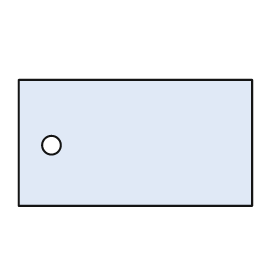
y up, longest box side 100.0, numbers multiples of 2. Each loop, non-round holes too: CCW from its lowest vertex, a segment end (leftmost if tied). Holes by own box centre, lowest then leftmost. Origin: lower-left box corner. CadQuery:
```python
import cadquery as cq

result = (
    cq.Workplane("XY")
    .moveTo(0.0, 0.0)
    .lineTo(100.0, 0.0)
    .lineTo(100.0, 54.0)
    .lineTo(0.0, 54.0)
    .close()
    .moveTo(14.0, 26.0)
    .circle(4.0)
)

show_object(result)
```